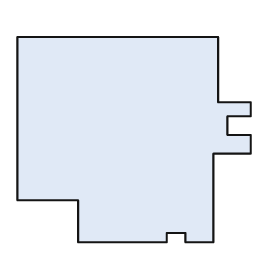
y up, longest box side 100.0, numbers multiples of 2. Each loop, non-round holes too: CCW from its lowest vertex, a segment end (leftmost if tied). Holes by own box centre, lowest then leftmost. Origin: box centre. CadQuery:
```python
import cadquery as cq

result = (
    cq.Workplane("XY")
    .moveTo(-24.0, -44.0)
    .lineTo(14.0, -44.0)
    .lineTo(14.0, -40.0)
    .lineTo(22.0, -40.0)
    .lineTo(22.0, -44.0)
    .lineTo(34.0, -44.0)
    .lineTo(34.0, -6.0)
    .lineTo(50.0, -6.0)
    .lineTo(50.0, 2.0)
    .lineTo(40.0, 2.0)
    .lineTo(40.0, 10.0)
    .lineTo(50.0, 10.0)
    .lineTo(50.0, 16.0)
    .lineTo(36.0, 16.0)
    .lineTo(36.0, 44.0)
    .lineTo(-50.0, 44.0)
    .lineTo(-50.0, -26.0)
    .lineTo(-24.0, -26.0)
    .close()
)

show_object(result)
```